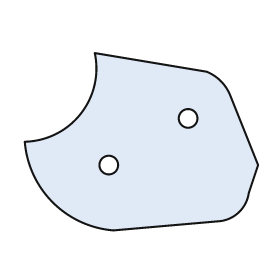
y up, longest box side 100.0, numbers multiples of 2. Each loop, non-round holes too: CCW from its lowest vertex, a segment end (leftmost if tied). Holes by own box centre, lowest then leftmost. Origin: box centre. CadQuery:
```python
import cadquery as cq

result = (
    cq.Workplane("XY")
    .moveTo(-12.0, -38.0)
    .lineTo(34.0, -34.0)
    .threePointArc((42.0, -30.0), (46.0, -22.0))
    .lineTo(50.0, -10.0)
    .lineTo(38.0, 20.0)
    .threePointArc((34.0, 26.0), (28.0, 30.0))
    .lineTo(-20.0, 38.0)
    .threePointArc((-26.0, 12.0), (-50.0, 0.0))
    .threePointArc((-38.0, -26.0), (-12.0, -38.0))
    .close()
    .moveTo(-14.0, -10.0)
    .circle(4.0)
    .moveTo(20.0, 10.0)
    .circle(4.0)
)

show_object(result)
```